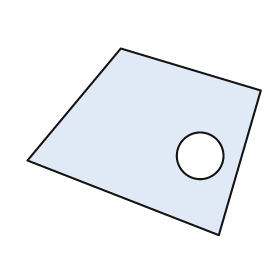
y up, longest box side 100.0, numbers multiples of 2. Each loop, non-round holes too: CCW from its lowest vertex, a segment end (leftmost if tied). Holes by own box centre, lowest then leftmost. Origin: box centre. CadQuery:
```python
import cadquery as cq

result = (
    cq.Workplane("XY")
    .moveTo(32.0, -40.0)
    .lineTo(50.0, 22.0)
    .lineTo(-10.0, 40.0)
    .lineTo(-50.0, -8.0)
    .close()
    .moveTo(24.0, -6.0)
    .circle(10.0)
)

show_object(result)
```